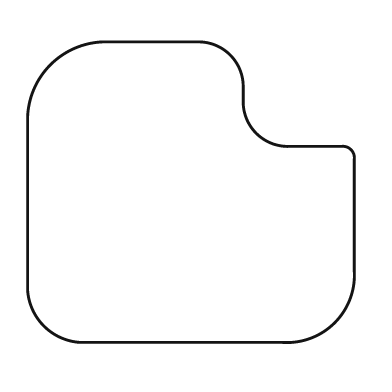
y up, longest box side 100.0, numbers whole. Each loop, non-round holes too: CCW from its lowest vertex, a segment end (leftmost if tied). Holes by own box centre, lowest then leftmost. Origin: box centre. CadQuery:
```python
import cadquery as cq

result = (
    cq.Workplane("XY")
    .moveTo(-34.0, -46.0)
    .lineTo(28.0, -46.0)
    .threePointArc((44.0, -40.0), (50.0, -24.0))
    .lineTo(50.0, 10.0)
    .threePointArc((49.0, 13.0), (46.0, 14.0))
    .lineTo(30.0, 14.0)
    .threePointArc((20.0, 18.0), (16.0, 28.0))
    .lineTo(16.0, 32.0)
    .threePointArc((12.0, 42.0), (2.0, 46.0))
    .lineTo(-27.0, 46.0)
    .threePointArc((-43.0, 39.0), (-50.0, 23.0))
    .lineTo(-50.0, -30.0)
    .threePointArc((-45.0, -41.0), (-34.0, -46.0))
    .close()
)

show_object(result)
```